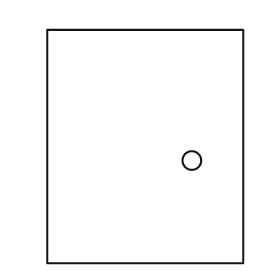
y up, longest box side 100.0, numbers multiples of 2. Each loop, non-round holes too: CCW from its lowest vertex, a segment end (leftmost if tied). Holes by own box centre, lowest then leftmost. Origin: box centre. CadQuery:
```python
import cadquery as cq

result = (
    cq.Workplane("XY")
    .moveTo(-42.0, -50.0)
    .lineTo(42.0, -50.0)
    .lineTo(42.0, 50.0)
    .lineTo(-42.0, 50.0)
    .close()
    .moveTo(20.0, -6.0)
    .circle(4.0)
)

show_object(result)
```